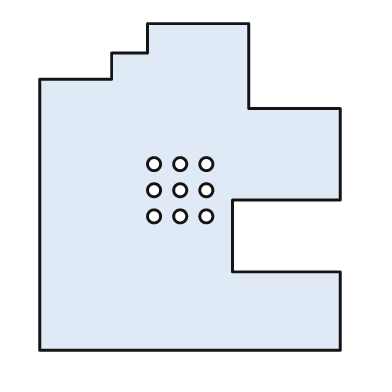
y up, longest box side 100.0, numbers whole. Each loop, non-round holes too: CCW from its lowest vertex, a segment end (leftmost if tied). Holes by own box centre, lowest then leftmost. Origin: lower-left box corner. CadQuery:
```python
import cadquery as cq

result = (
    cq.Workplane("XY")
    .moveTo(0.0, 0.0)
    .lineTo(92.0, 0.0)
    .lineTo(92.0, 24.0)
    .lineTo(59.0, 24.0)
    .lineTo(59.0, 46.0)
    .lineTo(92.0, 46.0)
    .lineTo(92.0, 74.0)
    .lineTo(64.0, 74.0)
    .lineTo(64.0, 100.0)
    .lineTo(33.0, 100.0)
    .lineTo(33.0, 91.0)
    .lineTo(22.0, 91.0)
    .lineTo(22.0, 83.0)
    .lineTo(0.0, 83.0)
    .close()
    .moveTo(35.0, 41.0)
    .circle(2.0)
    .moveTo(43.0, 41.0)
    .circle(2.0)
    .moveTo(51.0, 41.0)
    .circle(2.0)
    .moveTo(35.0, 49.0)
    .circle(2.0)
    .moveTo(43.0, 49.0)
    .circle(2.0)
    .moveTo(51.0, 49.0)
    .circle(2.0)
    .moveTo(35.0, 57.0)
    .circle(2.0)
    .moveTo(43.0, 57.0)
    .circle(2.0)
    .moveTo(51.0, 57.0)
    .circle(2.0)
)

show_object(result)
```